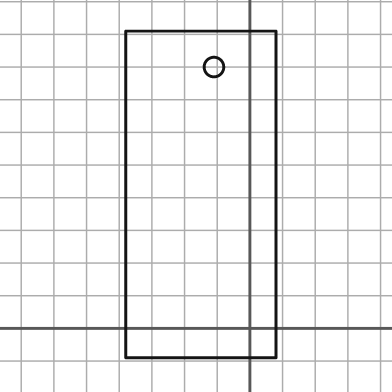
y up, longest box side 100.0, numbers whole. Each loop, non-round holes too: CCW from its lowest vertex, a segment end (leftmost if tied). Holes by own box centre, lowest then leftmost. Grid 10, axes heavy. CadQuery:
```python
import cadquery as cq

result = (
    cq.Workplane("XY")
    .moveTo(-38.0, -9.0)
    .lineTo(8.0, -9.0)
    .lineTo(8.0, 91.0)
    .lineTo(-38.0, 91.0)
    .close()
    .moveTo(-11.0, 80.0)
    .circle(3.0)
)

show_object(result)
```